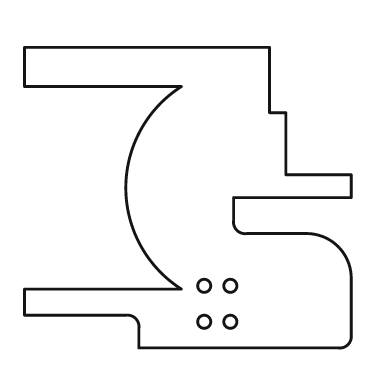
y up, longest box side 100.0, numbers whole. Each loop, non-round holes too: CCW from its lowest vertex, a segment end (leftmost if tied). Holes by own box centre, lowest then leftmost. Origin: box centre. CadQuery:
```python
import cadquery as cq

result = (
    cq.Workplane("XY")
    .moveTo(-15.0, -46.0)
    .lineTo(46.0, -46.0)
    .threePointArc((49.0, -45.0), (50.0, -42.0))
    .lineTo(50.0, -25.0)
    .threePointArc((46.0, -15.0), (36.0, -11.0))
    .lineTo(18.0, -11.0)
    .threePointArc((15.0, -10.0), (14.0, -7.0))
    .lineTo(14.0, 0.0)
    .lineTo(50.0, 0.0)
    .lineTo(50.0, 7.0)
    .lineTo(30.0, 7.0)
    .lineTo(30.0, 26.0)
    .lineTo(25.0, 26.0)
    .lineTo(25.0, 46.0)
    .lineTo(-50.0, 46.0)
    .lineTo(-50.0, 34.0)
    .lineTo(-2.0, 34.0)
    .threePointArc((-19.0, 3.0), (-2.0, -28.0))
    .lineTo(-50.0, -28.0)
    .lineTo(-50.0, -36.0)
    .lineTo(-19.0, -36.0)
    .threePointArc((-16.0, -37.0), (-15.0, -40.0))
    .close()
    .moveTo(5.0, -38.0)
    .circle(2.0)
    .moveTo(13.0, -38.0)
    .circle(2.0)
    .moveTo(5.0, -27.0)
    .circle(2.0)
    .moveTo(13.0, -27.0)
    .circle(2.0)
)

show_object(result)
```